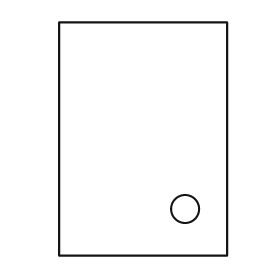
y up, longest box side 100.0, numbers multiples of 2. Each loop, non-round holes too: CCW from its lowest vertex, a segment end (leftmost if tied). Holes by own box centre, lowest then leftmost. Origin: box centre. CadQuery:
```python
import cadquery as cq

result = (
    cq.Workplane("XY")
    .moveTo(-36.0, -50.0)
    .lineTo(36.0, -50.0)
    .lineTo(36.0, 50.0)
    .lineTo(-36.0, 50.0)
    .close()
    .moveTo(18.0, -30.0)
    .circle(6.0)
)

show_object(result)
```